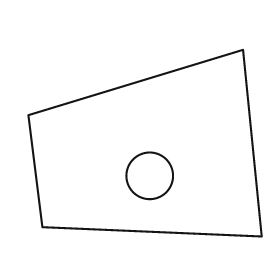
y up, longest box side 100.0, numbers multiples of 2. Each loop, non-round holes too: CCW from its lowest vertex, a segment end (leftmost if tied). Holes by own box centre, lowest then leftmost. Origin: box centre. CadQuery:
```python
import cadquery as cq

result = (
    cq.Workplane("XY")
    .moveTo(50.0, -40.0)
    .lineTo(42.0, 40.0)
    .lineTo(-50.0, 12.0)
    .lineTo(-44.0, -36.0)
    .close()
    .moveTo(2.0, -14.0)
    .circle(10.0)
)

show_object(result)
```